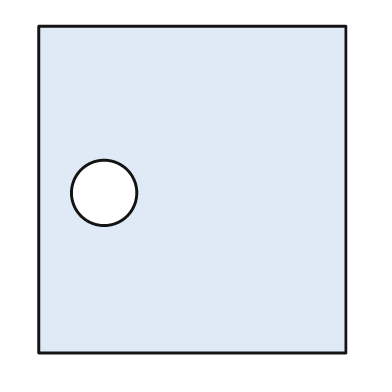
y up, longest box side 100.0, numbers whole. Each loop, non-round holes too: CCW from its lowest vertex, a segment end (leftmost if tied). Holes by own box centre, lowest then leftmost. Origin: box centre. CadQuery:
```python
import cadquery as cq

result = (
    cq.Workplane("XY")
    .moveTo(-47.0, -50.0)
    .lineTo(47.0, -50.0)
    .lineTo(47.0, 50.0)
    .lineTo(-47.0, 50.0)
    .close()
    .moveTo(-27.0, -1.0)
    .circle(10.0)
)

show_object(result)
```